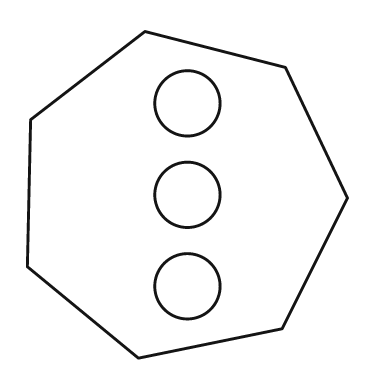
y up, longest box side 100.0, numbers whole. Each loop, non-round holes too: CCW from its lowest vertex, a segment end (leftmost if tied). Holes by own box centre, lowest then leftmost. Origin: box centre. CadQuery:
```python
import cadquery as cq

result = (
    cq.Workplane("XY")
    .moveTo(-15.0, -50.0)
    .lineTo(29.0, -41.0)
    .lineTo(49.0, -1.0)
    .lineTo(30.0, 39.0)
    .lineTo(-13.0, 50.0)
    .lineTo(-48.0, 23.0)
    .lineTo(-49.0, -22.0)
    .close()
    .moveTo(0.0, -28.0)
    .circle(10.0)
    .moveTo(0.0, 0.0)
    .circle(10.0)
    .moveTo(0.0, 28.0)
    .circle(10.0)
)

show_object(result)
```